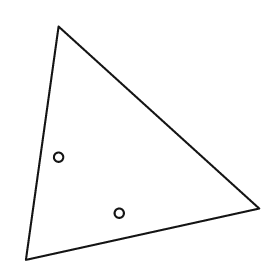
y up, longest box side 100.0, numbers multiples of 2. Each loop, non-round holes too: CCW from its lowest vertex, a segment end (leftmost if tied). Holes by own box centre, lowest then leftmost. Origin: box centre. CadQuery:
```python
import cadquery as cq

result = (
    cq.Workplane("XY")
    .moveTo(-50.0, -50.0)
    .lineTo(50.0, -28.0)
    .lineTo(-36.0, 50.0)
    .close()
    .moveTo(-10.0, -30.0)
    .circle(2.0)
    .moveTo(-36.0, -6.0)
    .circle(2.0)
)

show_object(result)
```